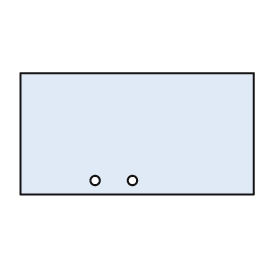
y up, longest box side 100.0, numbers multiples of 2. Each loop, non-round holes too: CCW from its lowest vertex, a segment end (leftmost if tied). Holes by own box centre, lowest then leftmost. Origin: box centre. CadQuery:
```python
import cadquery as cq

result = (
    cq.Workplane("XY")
    .moveTo(-50.0, -26.0)
    .lineTo(50.0, -26.0)
    .lineTo(50.0, 26.0)
    .lineTo(-50.0, 26.0)
    .close()
    .moveTo(-18.0, -20.0)
    .circle(2.0)
    .moveTo(-2.0, -20.0)
    .circle(2.0)
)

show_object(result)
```